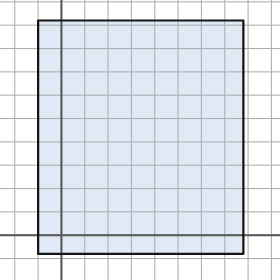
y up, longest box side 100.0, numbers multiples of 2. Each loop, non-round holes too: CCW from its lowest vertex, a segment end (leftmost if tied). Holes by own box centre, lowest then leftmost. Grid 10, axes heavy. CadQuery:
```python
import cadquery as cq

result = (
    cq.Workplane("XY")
    .moveTo(-10.0, -8.0)
    .lineTo(78.0, -8.0)
    .lineTo(78.0, 92.0)
    .lineTo(-10.0, 92.0)
    .close()
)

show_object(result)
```